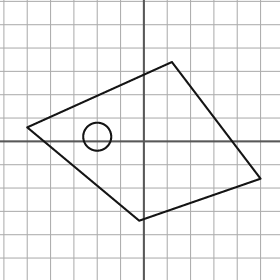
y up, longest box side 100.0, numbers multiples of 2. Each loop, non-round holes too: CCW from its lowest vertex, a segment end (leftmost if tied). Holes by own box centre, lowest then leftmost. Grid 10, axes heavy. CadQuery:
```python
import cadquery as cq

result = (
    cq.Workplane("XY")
    .moveTo(-2.0, -34.0)
    .lineTo(50.0, -16.0)
    .lineTo(12.0, 34.0)
    .lineTo(-50.0, 6.0)
    .close()
    .moveTo(-20.0, 2.0)
    .circle(6.0)
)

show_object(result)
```